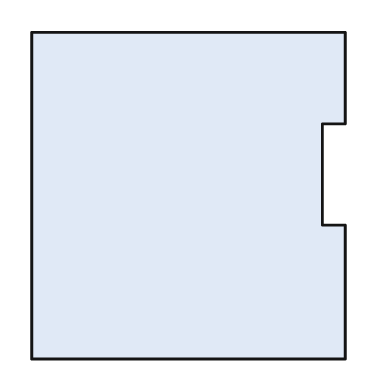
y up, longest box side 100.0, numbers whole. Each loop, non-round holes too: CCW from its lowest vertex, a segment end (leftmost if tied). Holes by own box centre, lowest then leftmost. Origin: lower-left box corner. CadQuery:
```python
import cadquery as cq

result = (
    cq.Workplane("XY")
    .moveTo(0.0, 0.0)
    .lineTo(96.0, 0.0)
    .lineTo(96.0, 41.0)
    .lineTo(89.0, 41.0)
    .lineTo(89.0, 72.0)
    .lineTo(96.0, 72.0)
    .lineTo(96.0, 100.0)
    .lineTo(0.0, 100.0)
    .close()
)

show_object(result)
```